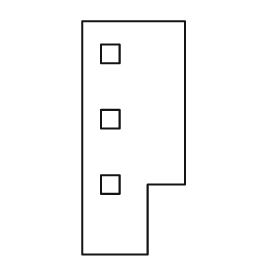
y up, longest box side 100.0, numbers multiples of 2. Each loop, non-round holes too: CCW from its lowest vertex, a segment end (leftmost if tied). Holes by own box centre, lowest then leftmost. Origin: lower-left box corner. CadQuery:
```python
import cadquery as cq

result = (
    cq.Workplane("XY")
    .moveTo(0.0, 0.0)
    .lineTo(28.0, 0.0)
    .lineTo(28.0, 30.0)
    .lineTo(44.0, 30.0)
    .lineTo(44.0, 100.0)
    .lineTo(0.0, 100.0)
    .close()
    .moveTo(8.0, 26.0)
    .lineTo(16.0, 26.0)
    .lineTo(16.0, 34.0)
    .lineTo(8.0, 34.0)
    .close()
    .moveTo(8.0, 54.0)
    .lineTo(16.0, 54.0)
    .lineTo(16.0, 62.0)
    .lineTo(8.0, 62.0)
    .close()
    .moveTo(8.0, 82.0)
    .lineTo(16.0, 82.0)
    .lineTo(16.0, 90.0)
    .lineTo(8.0, 90.0)
    .close()
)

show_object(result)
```